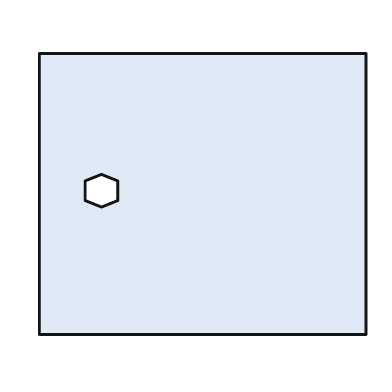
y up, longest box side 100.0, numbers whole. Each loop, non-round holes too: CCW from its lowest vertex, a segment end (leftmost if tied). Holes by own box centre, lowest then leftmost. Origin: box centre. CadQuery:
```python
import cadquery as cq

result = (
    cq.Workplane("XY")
    .moveTo(-50.0, -43.0)
    .lineTo(50.0, -43.0)
    .lineTo(50.0, 43.0)
    .lineTo(-50.0, 43.0)
    .close()
    .moveTo(-31.0, -4.0)
    .lineTo(-26.0, -2.0)
    .lineTo(-26.0, 4.0)
    .lineTo(-31.0, 6.0)
    .lineTo(-36.0, 4.0)
    .lineTo(-36.0, -2.0)
    .close()
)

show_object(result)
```